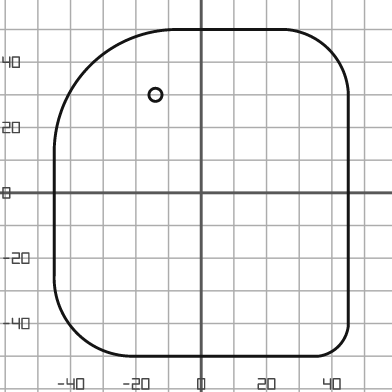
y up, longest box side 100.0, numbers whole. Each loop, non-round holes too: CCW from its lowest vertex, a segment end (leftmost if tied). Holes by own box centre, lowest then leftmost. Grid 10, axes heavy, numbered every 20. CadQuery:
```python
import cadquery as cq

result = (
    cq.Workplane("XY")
    .moveTo(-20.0, -50.0)
    .lineTo(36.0, -50.0)
    .threePointArc((42.0, -47.0), (45.0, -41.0))
    .lineTo(45.0, 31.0)
    .threePointArc((39.0, 44.0), (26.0, 50.0))
    .lineTo(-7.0, 50.0)
    .threePointArc((-34.0, 39.0), (-45.0, 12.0))
    .lineTo(-45.0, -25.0)
    .threePointArc((-38.0, -43.0), (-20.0, -50.0))
    .close()
    .moveTo(-14.0, 30.0)
    .circle(2.0)
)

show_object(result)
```